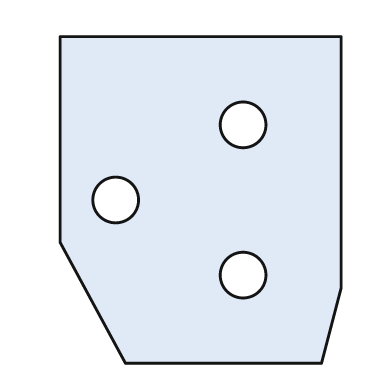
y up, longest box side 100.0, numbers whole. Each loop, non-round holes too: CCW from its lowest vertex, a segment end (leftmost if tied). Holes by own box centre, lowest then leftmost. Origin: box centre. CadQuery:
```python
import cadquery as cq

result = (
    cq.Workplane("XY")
    .moveTo(-23.0, -50.0)
    .lineTo(37.0, -50.0)
    .lineTo(43.0, -27.0)
    .lineTo(43.0, 50.0)
    .lineTo(-43.0, 50.0)
    .lineTo(-43.0, -13.0)
    .close()
    .moveTo(13.0, -23.0)
    .circle(7.0)
    .moveTo(-26.0, 0.0)
    .circle(7.0)
    .moveTo(13.0, 23.0)
    .circle(7.0)
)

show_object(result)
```